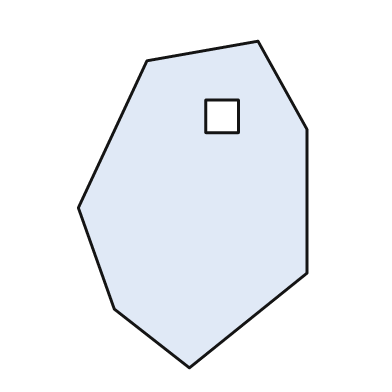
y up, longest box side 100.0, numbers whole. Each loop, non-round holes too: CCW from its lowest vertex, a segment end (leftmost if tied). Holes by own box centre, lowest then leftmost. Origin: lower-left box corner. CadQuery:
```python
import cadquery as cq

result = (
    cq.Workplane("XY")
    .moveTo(34.0, 0.0)
    .lineTo(70.0, 29.0)
    .lineTo(70.0, 73.0)
    .lineTo(55.0, 100.0)
    .lineTo(21.0, 94.0)
    .lineTo(0.0, 49.0)
    .lineTo(11.0, 18.0)
    .close()
    .moveTo(39.0, 72.0)
    .lineTo(49.0, 72.0)
    .lineTo(49.0, 82.0)
    .lineTo(39.0, 82.0)
    .close()
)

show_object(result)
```